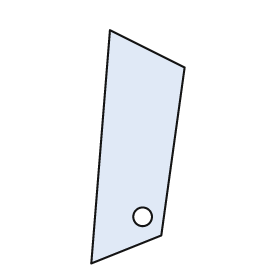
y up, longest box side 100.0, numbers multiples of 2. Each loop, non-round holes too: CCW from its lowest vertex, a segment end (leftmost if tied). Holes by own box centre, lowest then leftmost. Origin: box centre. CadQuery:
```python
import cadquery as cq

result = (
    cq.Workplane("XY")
    .moveTo(-20.0, -50.0)
    .lineTo(10.0, -38.0)
    .lineTo(20.0, 34.0)
    .lineTo(-12.0, 50.0)
    .close()
    .moveTo(2.0, -30.0)
    .circle(4.0)
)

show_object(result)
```